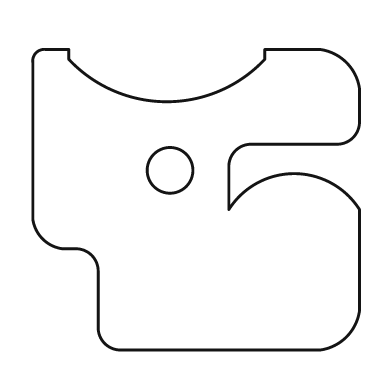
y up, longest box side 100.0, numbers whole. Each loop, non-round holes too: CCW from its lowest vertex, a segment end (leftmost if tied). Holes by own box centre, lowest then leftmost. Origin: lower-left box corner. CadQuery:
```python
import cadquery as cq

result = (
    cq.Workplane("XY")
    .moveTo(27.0, 0.0)
    .lineTo(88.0, 0.0)
    .threePointArc((96.0, 4.0), (100.0, 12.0))
    .lineTo(100.0, 43.0)
    .threePointArc((80.0, 54.0), (60.0, 43.0))
    .lineTo(60.0, 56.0)
    .threePointArc((62.0, 61.0), (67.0, 63.0))
    .lineTo(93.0, 63.0)
    .threePointArc((98.0, 65.0), (100.0, 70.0))
    .lineTo(100.0, 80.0)
    .threePointArc((96.0, 88.0), (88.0, 92.0))
    .lineTo(71.0, 92.0)
    .lineTo(71.0, 89.0)
    .threePointArc((41.0, 76.0), (11.0, 89.0))
    .lineTo(11.0, 92.0)
    .lineTo(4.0, 92.0)
    .threePointArc((1.0, 91.0), (0.0, 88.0))
    .lineTo(0.0, 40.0)
    .threePointArc((3.0, 34.0), (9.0, 31.0))
    .lineTo(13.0, 31.0)
    .threePointArc((18.0, 29.0), (20.0, 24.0))
    .lineTo(20.0, 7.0)
    .threePointArc((22.0, 2.0), (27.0, 0.0))
    .close()
    .moveTo(42.0, 55.0)
    .circle(7.0)
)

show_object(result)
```